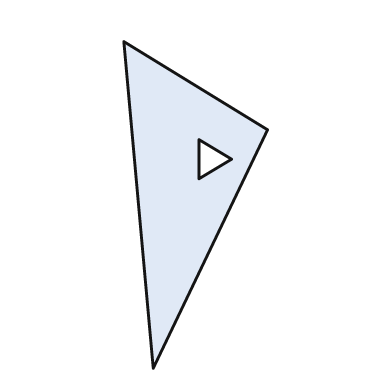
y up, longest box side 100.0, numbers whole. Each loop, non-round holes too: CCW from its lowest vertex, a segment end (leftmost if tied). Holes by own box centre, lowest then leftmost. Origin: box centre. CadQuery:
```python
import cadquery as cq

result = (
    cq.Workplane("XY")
    .moveTo(-13.0, -50.0)
    .lineTo(22.0, 23.0)
    .lineTo(-22.0, 50.0)
    .close()
    .moveTo(1.0, 8.0)
    .lineTo(11.0, 14.0)
    .lineTo(1.0, 20.0)
    .close()
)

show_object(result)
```